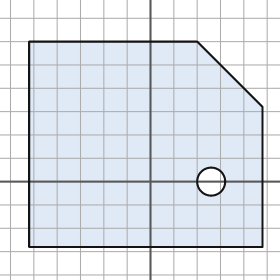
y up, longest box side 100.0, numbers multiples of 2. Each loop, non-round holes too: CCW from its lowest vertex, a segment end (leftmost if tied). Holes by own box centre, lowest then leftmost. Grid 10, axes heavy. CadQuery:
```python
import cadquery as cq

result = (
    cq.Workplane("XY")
    .moveTo(-52.0, -28.0)
    .lineTo(48.0, -28.0)
    .lineTo(48.0, 32.0)
    .lineTo(20.0, 60.0)
    .lineTo(-52.0, 60.0)
    .close()
    .moveTo(26.0, 0.0)
    .circle(6.0)
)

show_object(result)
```